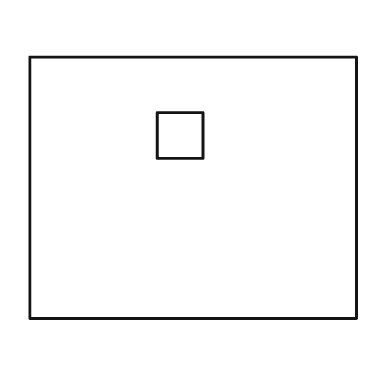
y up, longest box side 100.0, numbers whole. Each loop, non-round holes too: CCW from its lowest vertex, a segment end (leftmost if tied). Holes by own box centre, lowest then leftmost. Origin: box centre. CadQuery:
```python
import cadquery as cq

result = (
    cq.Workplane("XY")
    .moveTo(-50.0, -40.0)
    .lineTo(50.0, -40.0)
    .lineTo(50.0, 40.0)
    .lineTo(-50.0, 40.0)
    .close()
    .moveTo(-11.0, 9.0)
    .lineTo(3.0, 9.0)
    .lineTo(3.0, 23.0)
    .lineTo(-11.0, 23.0)
    .close()
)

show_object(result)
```